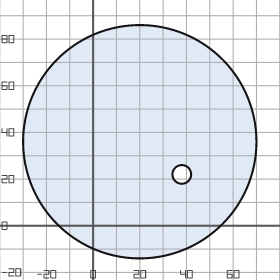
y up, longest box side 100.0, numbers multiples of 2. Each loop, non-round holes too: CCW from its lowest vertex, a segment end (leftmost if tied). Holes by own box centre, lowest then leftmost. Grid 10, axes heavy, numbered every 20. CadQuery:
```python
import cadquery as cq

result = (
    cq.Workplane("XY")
    .moveTo(20.0, 36.0)
    .circle(50.0)
    .moveTo(38.0, 22.0)
    .circle(4.0)
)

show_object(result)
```